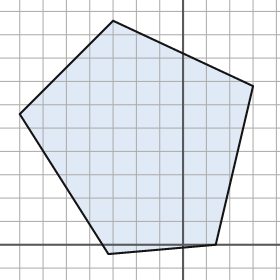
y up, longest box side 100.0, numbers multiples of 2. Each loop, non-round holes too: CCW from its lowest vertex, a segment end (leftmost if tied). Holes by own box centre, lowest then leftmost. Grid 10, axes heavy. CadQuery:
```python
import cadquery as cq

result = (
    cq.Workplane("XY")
    .moveTo(-32.0, -4.0)
    .lineTo(14.0, 0.0)
    .lineTo(30.0, 68.0)
    .lineTo(-30.0, 96.0)
    .lineTo(-70.0, 56.0)
    .close()
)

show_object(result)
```